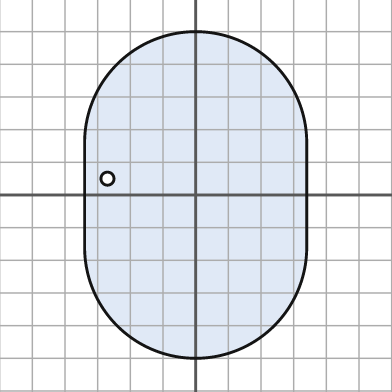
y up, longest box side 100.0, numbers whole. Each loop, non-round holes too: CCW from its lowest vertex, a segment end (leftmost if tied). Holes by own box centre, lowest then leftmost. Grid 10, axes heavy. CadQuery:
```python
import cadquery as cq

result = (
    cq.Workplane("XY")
    .moveTo(-34.0, -16.0)
    .threePointArc((0.0, -50.0), (34.0, -16.0))
    .lineTo(34.0, 16.0)
    .threePointArc((0.0, 50.0), (-34.0, 16.0))
    .close()
    .moveTo(-27.0, 5.0)
    .circle(2.0)
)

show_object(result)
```